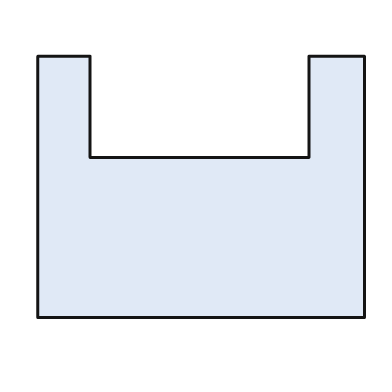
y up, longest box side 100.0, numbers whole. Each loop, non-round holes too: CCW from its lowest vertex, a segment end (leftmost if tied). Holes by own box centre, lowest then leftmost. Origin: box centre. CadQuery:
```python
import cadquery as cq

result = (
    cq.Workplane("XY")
    .moveTo(-50.0, -40.0)
    .lineTo(50.0, -40.0)
    .lineTo(50.0, 40.0)
    .lineTo(33.0, 40.0)
    .lineTo(33.0, 9.0)
    .lineTo(-34.0, 9.0)
    .lineTo(-34.0, 40.0)
    .lineTo(-50.0, 40.0)
    .close()
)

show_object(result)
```